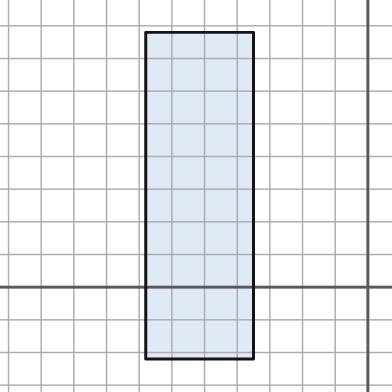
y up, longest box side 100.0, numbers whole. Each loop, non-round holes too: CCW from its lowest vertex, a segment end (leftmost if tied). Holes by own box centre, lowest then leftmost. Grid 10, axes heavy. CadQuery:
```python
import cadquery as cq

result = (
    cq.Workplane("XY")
    .moveTo(-68.0, -22.0)
    .lineTo(-35.0, -22.0)
    .lineTo(-35.0, 78.0)
    .lineTo(-68.0, 78.0)
    .close()
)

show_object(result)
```